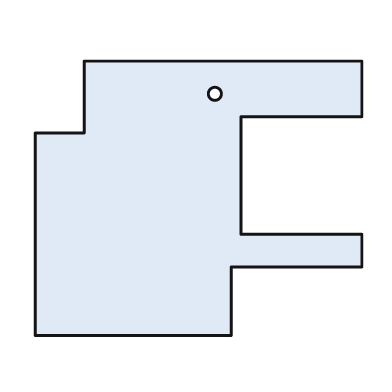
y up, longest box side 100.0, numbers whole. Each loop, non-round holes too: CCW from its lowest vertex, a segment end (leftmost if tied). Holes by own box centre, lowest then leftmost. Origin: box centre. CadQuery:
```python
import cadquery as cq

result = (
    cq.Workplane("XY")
    .moveTo(-50.0, -42.0)
    .lineTo(10.0, -42.0)
    .lineTo(10.0, -21.0)
    .lineTo(50.0, -21.0)
    .lineTo(50.0, -11.0)
    .lineTo(13.0, -11.0)
    .lineTo(13.0, 25.0)
    .lineTo(50.0, 25.0)
    .lineTo(50.0, 42.0)
    .lineTo(-35.0, 42.0)
    .lineTo(-35.0, 20.0)
    .lineTo(-50.0, 20.0)
    .close()
    .moveTo(5.0, 32.0)
    .circle(2.0)
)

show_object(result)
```